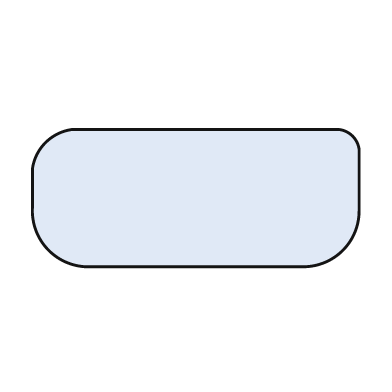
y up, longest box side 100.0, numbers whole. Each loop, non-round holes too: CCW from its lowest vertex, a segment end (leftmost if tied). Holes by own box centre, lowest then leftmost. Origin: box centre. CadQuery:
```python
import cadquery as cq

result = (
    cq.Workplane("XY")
    .moveTo(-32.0, -21.0)
    .lineTo(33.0, -21.0)
    .threePointArc((45.0, -16.0), (50.0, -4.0))
    .lineTo(50.0, 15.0)
    .threePointArc((48.0, 19.0), (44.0, 21.0))
    .lineTo(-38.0, 21.0)
    .threePointArc((-46.0, 17.0), (-50.0, 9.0))
    .lineTo(-50.0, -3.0)
    .threePointArc((-45.0, -16.0), (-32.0, -21.0))
    .close()
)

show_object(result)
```